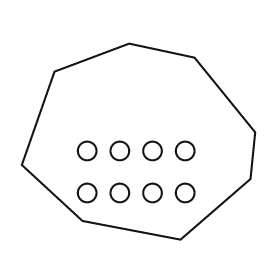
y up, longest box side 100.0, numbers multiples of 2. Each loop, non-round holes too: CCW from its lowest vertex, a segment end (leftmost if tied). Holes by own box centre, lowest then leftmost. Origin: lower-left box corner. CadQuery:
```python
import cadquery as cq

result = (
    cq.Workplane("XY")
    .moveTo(68.0, 0.0)
    .lineTo(98.0, 26.0)
    .lineTo(100.0, 46.0)
    .lineTo(74.0, 78.0)
    .lineTo(46.0, 84.0)
    .lineTo(14.0, 72.0)
    .lineTo(0.0, 32.0)
    .lineTo(26.0, 8.0)
    .close()
    .moveTo(28.0, 20.0)
    .circle(4.0)
    .moveTo(42.0, 20.0)
    .circle(4.0)
    .moveTo(56.0, 20.0)
    .circle(4.0)
    .moveTo(70.0, 20.0)
    .circle(4.0)
    .moveTo(28.0, 38.0)
    .circle(4.0)
    .moveTo(42.0, 38.0)
    .circle(4.0)
    .moveTo(56.0, 38.0)
    .circle(4.0)
    .moveTo(70.0, 38.0)
    .circle(4.0)
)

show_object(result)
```